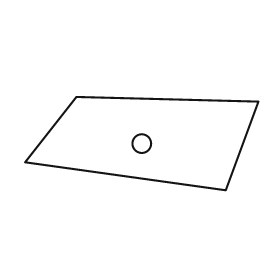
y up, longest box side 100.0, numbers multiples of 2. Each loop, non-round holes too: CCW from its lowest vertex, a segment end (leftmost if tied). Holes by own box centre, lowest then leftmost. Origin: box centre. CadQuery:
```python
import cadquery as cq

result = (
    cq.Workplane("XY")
    .moveTo(36.0, -20.0)
    .lineTo(50.0, 18.0)
    .lineTo(-28.0, 20.0)
    .lineTo(-50.0, -8.0)
    .close()
    .moveTo(0.0, 0.0)
    .circle(4.0)
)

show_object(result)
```